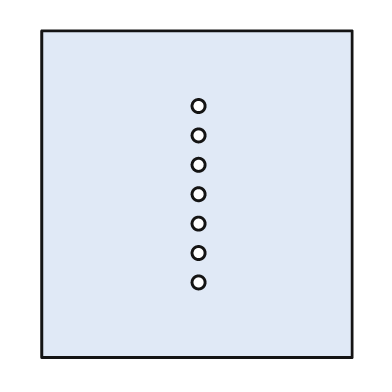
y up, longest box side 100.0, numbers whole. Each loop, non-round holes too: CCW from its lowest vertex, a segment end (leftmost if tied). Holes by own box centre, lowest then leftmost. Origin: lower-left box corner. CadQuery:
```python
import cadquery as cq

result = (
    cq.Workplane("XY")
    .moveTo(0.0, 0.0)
    .lineTo(95.0, 0.0)
    .lineTo(95.0, 100.0)
    .lineTo(0.0, 100.0)
    .close()
    .moveTo(48.0, 23.0)
    .circle(2.0)
    .moveTo(48.0, 32.0)
    .circle(2.0)
    .moveTo(48.0, 41.0)
    .circle(2.0)
    .moveTo(48.0, 50.0)
    .circle(2.0)
    .moveTo(48.0, 59.0)
    .circle(2.0)
    .moveTo(48.0, 68.0)
    .circle(2.0)
    .moveTo(48.0, 77.0)
    .circle(2.0)
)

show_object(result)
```